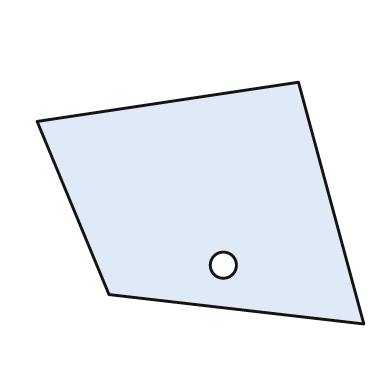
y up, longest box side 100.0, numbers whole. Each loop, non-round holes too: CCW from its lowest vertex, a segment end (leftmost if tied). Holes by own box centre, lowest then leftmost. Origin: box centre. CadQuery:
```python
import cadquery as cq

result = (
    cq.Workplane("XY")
    .moveTo(50.0, -37.0)
    .lineTo(30.0, 37.0)
    .lineTo(-50.0, 25.0)
    .lineTo(-28.0, -28.0)
    .close()
    .moveTo(7.0, -19.0)
    .circle(4.0)
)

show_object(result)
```